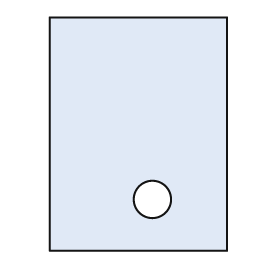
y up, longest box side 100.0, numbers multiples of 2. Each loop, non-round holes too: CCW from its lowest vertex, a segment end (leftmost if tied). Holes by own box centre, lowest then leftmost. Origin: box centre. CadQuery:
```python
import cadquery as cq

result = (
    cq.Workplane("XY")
    .moveTo(-38.0, -50.0)
    .lineTo(38.0, -50.0)
    .lineTo(38.0, 50.0)
    .lineTo(-38.0, 50.0)
    .close()
    .moveTo(6.0, -28.0)
    .circle(8.0)
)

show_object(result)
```